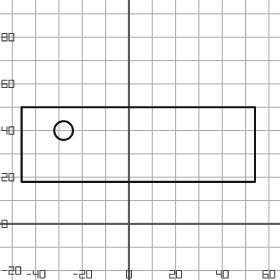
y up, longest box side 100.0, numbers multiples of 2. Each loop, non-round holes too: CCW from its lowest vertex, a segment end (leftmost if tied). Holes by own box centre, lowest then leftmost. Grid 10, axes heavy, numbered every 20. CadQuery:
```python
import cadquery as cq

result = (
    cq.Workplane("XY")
    .moveTo(-46.0, 18.0)
    .lineTo(54.0, 18.0)
    .lineTo(54.0, 50.0)
    .lineTo(-46.0, 50.0)
    .close()
    .moveTo(-28.0, 40.0)
    .circle(4.0)
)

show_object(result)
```